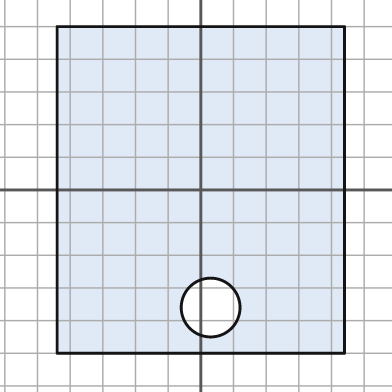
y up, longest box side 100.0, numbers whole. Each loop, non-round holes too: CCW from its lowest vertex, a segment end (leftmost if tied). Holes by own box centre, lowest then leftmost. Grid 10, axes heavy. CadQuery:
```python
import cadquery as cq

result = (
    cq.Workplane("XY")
    .moveTo(-44.0, -50.0)
    .lineTo(44.0, -50.0)
    .lineTo(44.0, 50.0)
    .lineTo(-44.0, 50.0)
    .close()
    .moveTo(3.0, -36.0)
    .circle(9.0)
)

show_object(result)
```